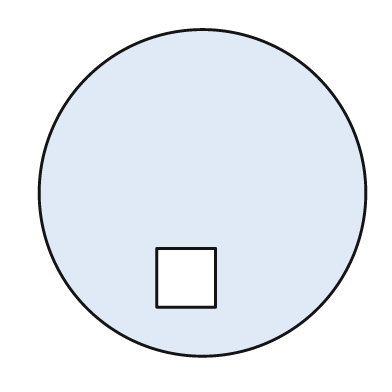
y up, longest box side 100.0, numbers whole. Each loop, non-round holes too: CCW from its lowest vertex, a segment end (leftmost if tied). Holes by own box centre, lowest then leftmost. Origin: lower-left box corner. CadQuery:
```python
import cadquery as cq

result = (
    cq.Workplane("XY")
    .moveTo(50.0, 50.0)
    .circle(50.0)
    .moveTo(36.0, 15.0)
    .lineTo(54.0, 15.0)
    .lineTo(54.0, 33.0)
    .lineTo(36.0, 33.0)
    .close()
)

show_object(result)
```